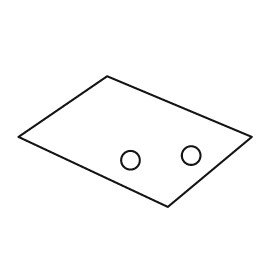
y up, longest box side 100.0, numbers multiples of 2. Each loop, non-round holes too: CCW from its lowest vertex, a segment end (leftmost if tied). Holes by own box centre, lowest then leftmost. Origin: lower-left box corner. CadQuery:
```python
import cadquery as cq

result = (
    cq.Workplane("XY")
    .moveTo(64.0, 0.0)
    .lineTo(100.0, 30.0)
    .lineTo(38.0, 56.0)
    .lineTo(0.0, 30.0)
    .close()
    .moveTo(48.0, 20.0)
    .circle(4.0)
    .moveTo(74.0, 22.0)
    .circle(4.0)
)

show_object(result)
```